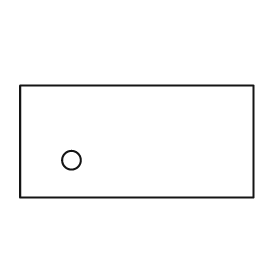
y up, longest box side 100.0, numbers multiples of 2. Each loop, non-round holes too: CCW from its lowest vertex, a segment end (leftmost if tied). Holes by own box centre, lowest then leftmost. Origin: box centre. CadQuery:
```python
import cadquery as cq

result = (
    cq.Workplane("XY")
    .moveTo(-50.0, -24.0)
    .lineTo(50.0, -24.0)
    .lineTo(50.0, 24.0)
    .lineTo(-50.0, 24.0)
    .close()
    .moveTo(-28.0, -8.0)
    .circle(4.0)
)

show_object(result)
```